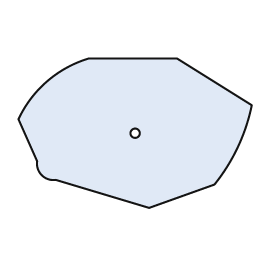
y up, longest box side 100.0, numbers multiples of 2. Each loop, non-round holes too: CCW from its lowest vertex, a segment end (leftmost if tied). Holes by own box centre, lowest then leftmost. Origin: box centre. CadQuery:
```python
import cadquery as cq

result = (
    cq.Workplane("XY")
    .moveTo(6.0, -32.0)
    .lineTo(34.0, -22.0)
    .threePointArc((44.0, -6.0), (50.0, 12.0))
    .lineTo(18.0, 32.0)
    .lineTo(-20.0, 32.0)
    .threePointArc((-38.0, 22.0), (-50.0, 6.0))
    .lineTo(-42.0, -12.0)
    .threePointArc((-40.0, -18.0), (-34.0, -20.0))
    .close()
    .moveTo(0.0, 0.0)
    .circle(2.0)
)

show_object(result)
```